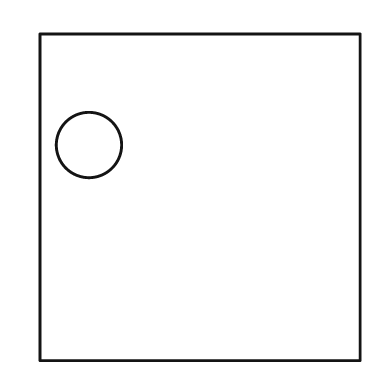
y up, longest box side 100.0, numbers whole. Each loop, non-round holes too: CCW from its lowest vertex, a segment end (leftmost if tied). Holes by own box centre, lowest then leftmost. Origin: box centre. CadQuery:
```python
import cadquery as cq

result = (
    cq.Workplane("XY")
    .moveTo(-49.0, -50.0)
    .lineTo(49.0, -50.0)
    .lineTo(49.0, 50.0)
    .lineTo(-49.0, 50.0)
    .close()
    .moveTo(-34.0, 16.0)
    .circle(10.0)
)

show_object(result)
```